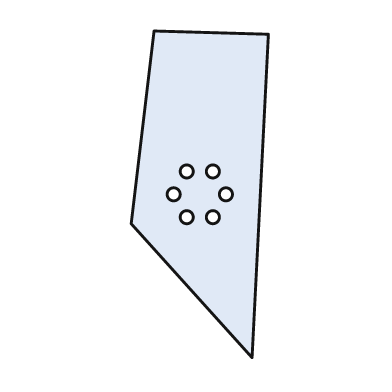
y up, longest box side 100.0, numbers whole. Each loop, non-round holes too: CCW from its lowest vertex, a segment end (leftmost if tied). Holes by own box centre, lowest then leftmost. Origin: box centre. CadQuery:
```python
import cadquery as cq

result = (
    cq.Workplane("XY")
    .moveTo(16.0, -50.0)
    .lineTo(21.0, 49.0)
    .lineTo(-14.0, 50.0)
    .lineTo(-21.0, -9.0)
    .close()
    .moveTo(-4.0, -7.0)
    .circle(2.0)
    .moveTo(4.0, -7.0)
    .circle(2.0)
    .moveTo(-8.0, 0.0)
    .circle(2.0)
    .moveTo(8.0, 0.0)
    .circle(2.0)
    .moveTo(-4.0, 7.0)
    .circle(2.0)
    .moveTo(4.0, 7.0)
    .circle(2.0)
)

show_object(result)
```